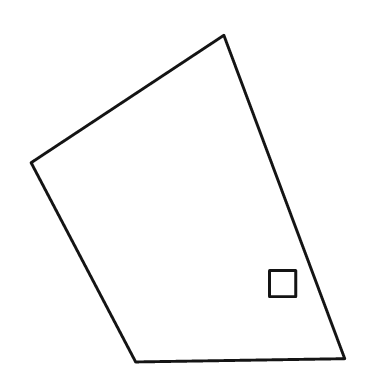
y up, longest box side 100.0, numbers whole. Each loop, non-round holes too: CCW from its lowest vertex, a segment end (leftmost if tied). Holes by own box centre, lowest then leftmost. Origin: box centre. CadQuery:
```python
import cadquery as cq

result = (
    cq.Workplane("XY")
    .moveTo(-16.0, -50.0)
    .lineTo(48.0, -49.0)
    .lineTo(11.0, 50.0)
    .lineTo(-48.0, 11.0)
    .close()
    .moveTo(25.0, -30.0)
    .lineTo(33.0, -30.0)
    .lineTo(33.0, -22.0)
    .lineTo(25.0, -22.0)
    .close()
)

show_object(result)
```